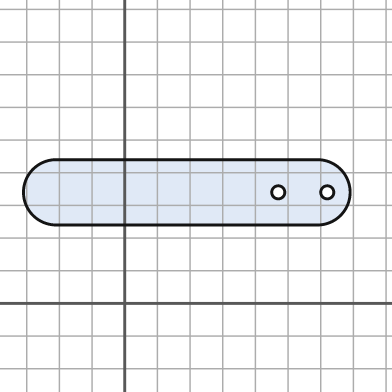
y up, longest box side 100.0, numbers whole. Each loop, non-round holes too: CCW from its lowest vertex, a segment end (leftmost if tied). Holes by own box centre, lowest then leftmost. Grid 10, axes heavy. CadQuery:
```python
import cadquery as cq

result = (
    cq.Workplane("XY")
    .moveTo(-21.0, 24.0)
    .lineTo(59.0, 24.0)
    .threePointArc((69.0, 34.0), (59.0, 44.0))
    .lineTo(-21.0, 44.0)
    .threePointArc((-31.0, 34.0), (-21.0, 24.0))
    .close()
    .moveTo(47.0, 34.0)
    .circle(2.0)
    .moveTo(62.0, 34.0)
    .circle(2.0)
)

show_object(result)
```